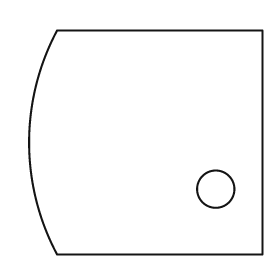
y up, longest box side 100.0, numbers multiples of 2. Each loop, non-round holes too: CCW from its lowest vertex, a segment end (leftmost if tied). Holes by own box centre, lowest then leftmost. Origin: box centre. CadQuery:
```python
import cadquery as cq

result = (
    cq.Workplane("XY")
    .moveTo(-38.0, -48.0)
    .lineTo(50.0, -48.0)
    .lineTo(50.0, 48.0)
    .lineTo(-38.0, 48.0)
    .threePointArc((-50.0, 0.0), (-38.0, -48.0))
    .close()
    .moveTo(30.0, -20.0)
    .circle(8.0)
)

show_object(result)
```